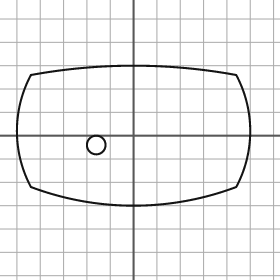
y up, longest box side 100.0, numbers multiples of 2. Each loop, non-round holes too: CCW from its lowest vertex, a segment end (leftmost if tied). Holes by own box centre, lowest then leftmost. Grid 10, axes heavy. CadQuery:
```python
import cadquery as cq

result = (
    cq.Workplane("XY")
    .moveTo(-44.0, -22.0)
    .threePointArc((0.0, -30.0), (44.0, -22.0))
    .threePointArc((50.0, 2.0), (44.0, 26.0))
    .threePointArc((0.0, 30.0), (-44.0, 26.0))
    .threePointArc((-50.0, 2.0), (-44.0, -22.0))
    .close()
    .moveTo(-16.0, -4.0)
    .circle(4.0)
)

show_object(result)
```